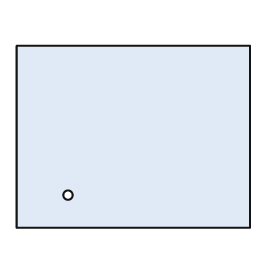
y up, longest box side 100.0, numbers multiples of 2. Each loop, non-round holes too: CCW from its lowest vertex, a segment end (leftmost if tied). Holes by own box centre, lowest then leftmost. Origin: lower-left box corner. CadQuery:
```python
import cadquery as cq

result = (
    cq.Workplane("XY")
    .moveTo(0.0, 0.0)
    .lineTo(100.0, 0.0)
    .lineTo(100.0, 78.0)
    .lineTo(0.0, 78.0)
    .close()
    .moveTo(22.0, 14.0)
    .circle(2.0)
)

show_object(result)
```